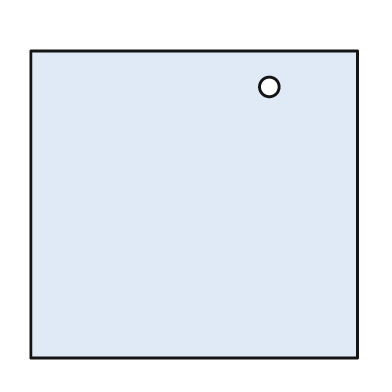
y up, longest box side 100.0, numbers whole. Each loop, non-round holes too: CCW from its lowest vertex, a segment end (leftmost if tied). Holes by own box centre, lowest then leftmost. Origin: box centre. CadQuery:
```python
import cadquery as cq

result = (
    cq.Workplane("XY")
    .moveTo(-50.0, -47.0)
    .lineTo(50.0, -47.0)
    .lineTo(50.0, 47.0)
    .lineTo(-50.0, 47.0)
    .close()
    .moveTo(23.0, 36.0)
    .circle(3.0)
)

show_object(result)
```